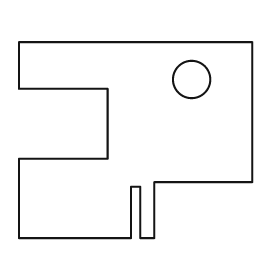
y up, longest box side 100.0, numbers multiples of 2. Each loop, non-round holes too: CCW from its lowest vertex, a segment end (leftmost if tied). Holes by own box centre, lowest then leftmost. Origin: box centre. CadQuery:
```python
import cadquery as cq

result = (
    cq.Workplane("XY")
    .moveTo(-50.0, -42.0)
    .lineTo(-2.0, -42.0)
    .lineTo(-2.0, -20.0)
    .lineTo(2.0, -20.0)
    .lineTo(2.0, -42.0)
    .lineTo(8.0, -42.0)
    .lineTo(8.0, -18.0)
    .lineTo(50.0, -18.0)
    .lineTo(50.0, 42.0)
    .lineTo(-50.0, 42.0)
    .lineTo(-50.0, 22.0)
    .lineTo(-12.0, 22.0)
    .lineTo(-12.0, -8.0)
    .lineTo(-50.0, -8.0)
    .close()
    .moveTo(24.0, 26.0)
    .circle(8.0)
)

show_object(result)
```